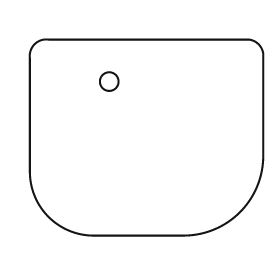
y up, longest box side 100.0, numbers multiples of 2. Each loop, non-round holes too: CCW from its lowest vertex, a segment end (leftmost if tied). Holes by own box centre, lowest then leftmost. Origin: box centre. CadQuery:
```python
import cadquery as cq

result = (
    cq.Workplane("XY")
    .moveTo(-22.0, -42.0)
    .lineTo(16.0, -42.0)
    .threePointArc((40.0, -32.0), (50.0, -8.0))
    .lineTo(50.0, 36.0)
    .threePointArc((48.0, 40.0), (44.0, 42.0))
    .lineTo(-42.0, 42.0)
    .threePointArc((-48.0, 40.0), (-50.0, 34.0))
    .lineTo(-50.0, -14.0)
    .threePointArc((-42.0, -34.0), (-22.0, -42.0))
    .close()
    .moveTo(-16.0, 24.0)
    .circle(4.0)
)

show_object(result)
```